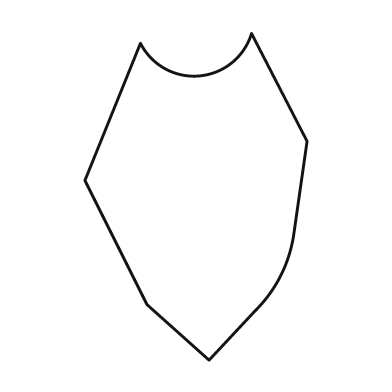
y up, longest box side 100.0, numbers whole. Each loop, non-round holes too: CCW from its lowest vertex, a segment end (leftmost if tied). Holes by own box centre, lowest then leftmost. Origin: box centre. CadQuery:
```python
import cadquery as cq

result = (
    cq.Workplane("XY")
    .moveTo(4.0, -50.0)
    .lineTo(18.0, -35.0)
    .threePointArc((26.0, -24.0), (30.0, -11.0))
    .lineTo(34.0, 17.0)
    .lineTo(17.0, 50.0)
    .threePointArc((1.0, 37.0), (-17.0, 47.0))
    .lineTo(-34.0, 5.0)
    .lineTo(-15.0, -33.0)
    .close()
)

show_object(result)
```